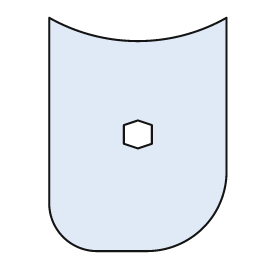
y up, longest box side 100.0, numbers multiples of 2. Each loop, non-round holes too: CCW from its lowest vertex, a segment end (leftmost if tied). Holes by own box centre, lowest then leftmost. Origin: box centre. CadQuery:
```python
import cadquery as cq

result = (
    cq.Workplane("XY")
    .moveTo(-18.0, -50.0)
    .lineTo(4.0, -50.0)
    .threePointArc((28.0, -40.0), (38.0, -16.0))
    .lineTo(38.0, 50.0)
    .threePointArc((0.0, 40.0), (-38.0, 50.0))
    .lineTo(-38.0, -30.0)
    .threePointArc((-32.0, -44.0), (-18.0, -50.0))
    .close()
    .moveTo(0.0, -6.0)
    .lineTo(6.0, -4.0)
    .lineTo(6.0, 4.0)
    .lineTo(0.0, 6.0)
    .lineTo(-6.0, 4.0)
    .lineTo(-6.0, -4.0)
    .close()
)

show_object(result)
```